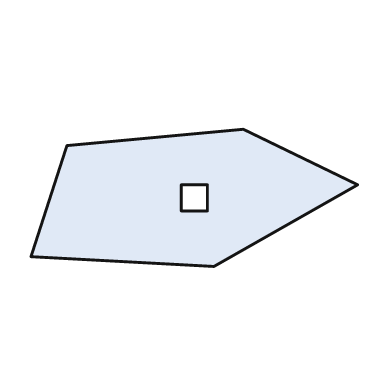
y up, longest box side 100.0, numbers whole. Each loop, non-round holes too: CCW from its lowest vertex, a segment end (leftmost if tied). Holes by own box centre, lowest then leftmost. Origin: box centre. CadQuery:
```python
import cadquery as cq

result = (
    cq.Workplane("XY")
    .moveTo(6.0, -21.0)
    .lineTo(50.0, 4.0)
    .lineTo(15.0, 21.0)
    .lineTo(-39.0, 16.0)
    .lineTo(-50.0, -18.0)
    .close()
    .moveTo(-4.0, -4.0)
    .lineTo(4.0, -4.0)
    .lineTo(4.0, 4.0)
    .lineTo(-4.0, 4.0)
    .close()
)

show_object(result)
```